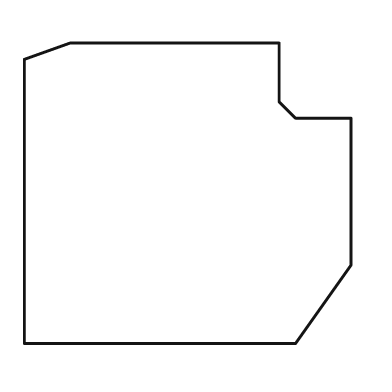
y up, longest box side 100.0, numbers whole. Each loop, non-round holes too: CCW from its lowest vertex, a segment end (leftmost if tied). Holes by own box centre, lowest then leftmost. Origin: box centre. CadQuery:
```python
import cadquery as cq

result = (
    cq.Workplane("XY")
    .moveTo(-50.0, -46.0)
    .lineTo(33.0, -46.0)
    .lineTo(50.0, -22.0)
    .lineTo(50.0, 23.0)
    .lineTo(33.0, 23.0)
    .lineTo(28.0, 28.0)
    .lineTo(28.0, 46.0)
    .lineTo(-36.0, 46.0)
    .lineTo(-50.0, 41.0)
    .close()
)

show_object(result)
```